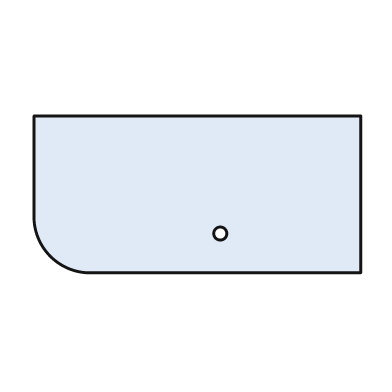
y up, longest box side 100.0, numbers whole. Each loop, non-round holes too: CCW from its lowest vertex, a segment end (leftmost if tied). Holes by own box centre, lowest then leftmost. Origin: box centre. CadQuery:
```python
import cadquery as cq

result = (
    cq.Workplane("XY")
    .moveTo(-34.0, -24.0)
    .lineTo(50.0, -24.0)
    .lineTo(50.0, 24.0)
    .lineTo(-50.0, 24.0)
    .lineTo(-50.0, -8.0)
    .threePointArc((-45.0, -19.0), (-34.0, -24.0))
    .close()
    .moveTo(7.0, -12.0)
    .circle(2.0)
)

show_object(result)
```